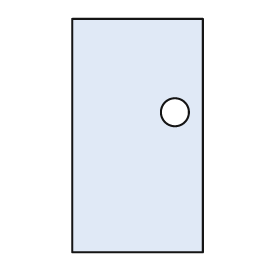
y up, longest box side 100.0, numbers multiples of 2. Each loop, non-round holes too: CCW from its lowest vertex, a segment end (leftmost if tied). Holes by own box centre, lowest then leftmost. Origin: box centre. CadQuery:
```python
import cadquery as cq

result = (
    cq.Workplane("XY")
    .moveTo(-28.0, -50.0)
    .lineTo(28.0, -50.0)
    .lineTo(28.0, 50.0)
    .lineTo(-28.0, 50.0)
    .close()
    .moveTo(16.0, 10.0)
    .circle(6.0)
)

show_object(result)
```